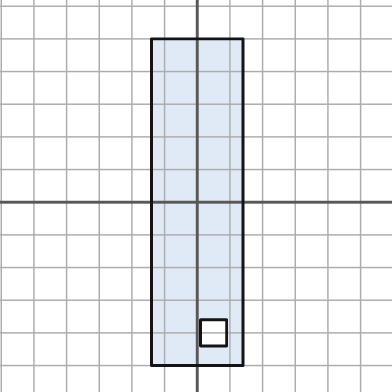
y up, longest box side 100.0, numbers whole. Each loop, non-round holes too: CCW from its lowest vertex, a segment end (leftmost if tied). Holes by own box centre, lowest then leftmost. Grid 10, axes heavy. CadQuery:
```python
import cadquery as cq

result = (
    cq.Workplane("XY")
    .moveTo(-14.0, -50.0)
    .lineTo(14.0, -50.0)
    .lineTo(14.0, 50.0)
    .lineTo(-14.0, 50.0)
    .close()
    .moveTo(1.0, -44.0)
    .lineTo(9.0, -44.0)
    .lineTo(9.0, -36.0)
    .lineTo(1.0, -36.0)
    .close()
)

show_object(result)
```